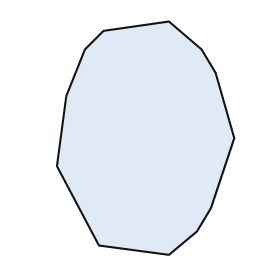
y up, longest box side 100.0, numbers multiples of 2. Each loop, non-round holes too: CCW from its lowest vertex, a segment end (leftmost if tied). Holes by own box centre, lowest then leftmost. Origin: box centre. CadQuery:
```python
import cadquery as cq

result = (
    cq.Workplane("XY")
    .moveTo(10.0, -50.0)
    .lineTo(22.0, -40.0)
    .lineTo(28.0, -30.0)
    .lineTo(38.0, 0.0)
    .lineTo(30.0, 28.0)
    .lineTo(24.0, 38.0)
    .lineTo(10.0, 50.0)
    .lineTo(-18.0, 46.0)
    .lineTo(-26.0, 38.0)
    .lineTo(-34.0, 18.0)
    .lineTo(-38.0, -12.0)
    .lineTo(-20.0, -46.0)
    .close()
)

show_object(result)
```